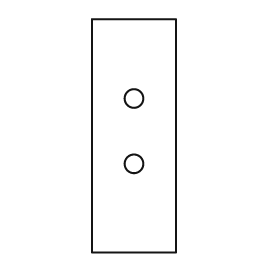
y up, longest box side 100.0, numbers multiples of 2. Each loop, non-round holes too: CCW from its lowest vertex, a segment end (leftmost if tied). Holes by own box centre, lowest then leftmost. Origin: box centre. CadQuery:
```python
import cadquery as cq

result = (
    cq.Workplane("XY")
    .moveTo(-18.0, -50.0)
    .lineTo(18.0, -50.0)
    .lineTo(18.0, 50.0)
    .lineTo(-18.0, 50.0)
    .close()
    .moveTo(0.0, -12.0)
    .circle(4.0)
    .moveTo(0.0, 16.0)
    .circle(4.0)
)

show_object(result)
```